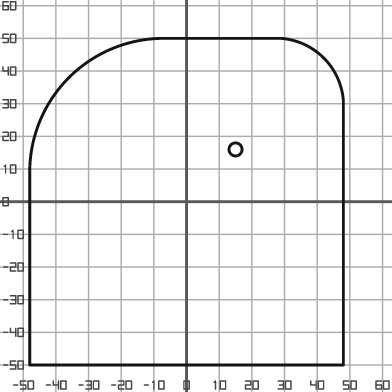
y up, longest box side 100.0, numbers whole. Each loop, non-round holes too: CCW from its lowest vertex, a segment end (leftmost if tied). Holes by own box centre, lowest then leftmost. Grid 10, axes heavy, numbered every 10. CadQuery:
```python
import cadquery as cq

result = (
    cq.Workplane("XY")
    .moveTo(-48.0, -50.0)
    .lineTo(48.0, -50.0)
    .lineTo(48.0, 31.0)
    .threePointArc((42.0, 44.0), (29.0, 50.0))
    .lineTo(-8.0, 50.0)
    .threePointArc((-36.0, 38.0), (-48.0, 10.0))
    .close()
    .moveTo(15.0, 16.0)
    .circle(2.0)
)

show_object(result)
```